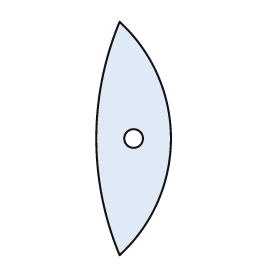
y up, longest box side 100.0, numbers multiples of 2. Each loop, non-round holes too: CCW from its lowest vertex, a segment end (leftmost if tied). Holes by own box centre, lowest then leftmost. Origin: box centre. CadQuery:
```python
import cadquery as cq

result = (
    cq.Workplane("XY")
    .moveTo(-6.0, -50.0)
    .threePointArc((16.0, 0.0), (-6.0, 50.0))
    .threePointArc((-16.0, 0.0), (-6.0, -50.0))
    .close()
    .moveTo(0.0, 0.0)
    .circle(4.0)
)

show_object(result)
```